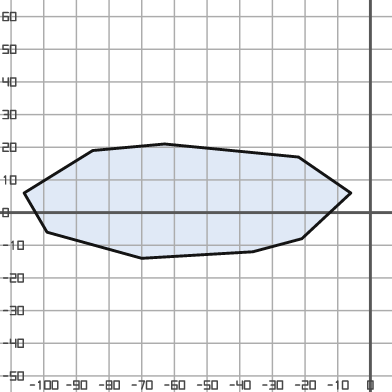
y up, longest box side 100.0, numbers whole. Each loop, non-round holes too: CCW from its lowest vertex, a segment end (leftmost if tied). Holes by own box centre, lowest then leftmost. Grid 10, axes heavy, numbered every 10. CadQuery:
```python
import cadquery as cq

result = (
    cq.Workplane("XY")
    .moveTo(-70.0, -14.0)
    .lineTo(-36.0, -12.0)
    .lineTo(-21.0, -8.0)
    .lineTo(-6.0, 6.0)
    .lineTo(-22.0, 17.0)
    .lineTo(-63.0, 21.0)
    .lineTo(-85.0, 19.0)
    .lineTo(-106.0, 6.0)
    .lineTo(-99.0, -6.0)
    .close()
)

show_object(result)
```